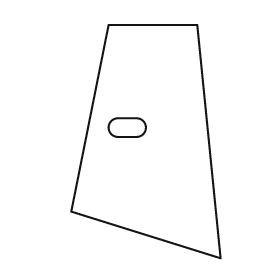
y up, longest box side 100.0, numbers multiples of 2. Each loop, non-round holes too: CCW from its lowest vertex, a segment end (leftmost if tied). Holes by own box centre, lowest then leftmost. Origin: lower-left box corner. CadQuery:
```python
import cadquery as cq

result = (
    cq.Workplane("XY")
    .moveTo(64.0, 0.0)
    .lineTo(54.0, 100.0)
    .lineTo(16.0, 100.0)
    .lineTo(0.0, 20.0)
    .close()
    .moveTo(20.0, 52.0)
    .lineTo(28.0, 52.0)
    .threePointArc((32.0, 56.0), (28.0, 60.0))
    .lineTo(20.0, 60.0)
    .threePointArc((16.0, 56.0), (20.0, 52.0))
    .close()
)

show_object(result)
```